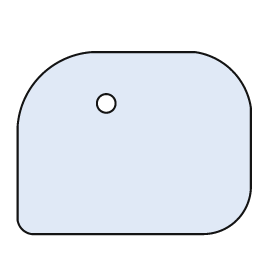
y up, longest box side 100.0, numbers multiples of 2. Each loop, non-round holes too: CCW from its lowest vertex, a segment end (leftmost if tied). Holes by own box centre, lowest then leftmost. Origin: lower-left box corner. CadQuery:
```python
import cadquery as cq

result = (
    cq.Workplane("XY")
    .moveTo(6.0, 0.0)
    .lineTo(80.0, 0.0)
    .threePointArc((94.0, 6.0), (100.0, 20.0))
    .lineTo(100.0, 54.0)
    .threePointArc((92.0, 70.0), (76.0, 78.0))
    .lineTo(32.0, 78.0)
    .threePointArc((10.0, 68.0), (0.0, 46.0))
    .lineTo(0.0, 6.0)
    .threePointArc((2.0, 2.0), (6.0, 0.0))
    .close()
    .moveTo(38.0, 56.0)
    .circle(4.0)
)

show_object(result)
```